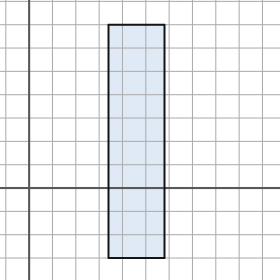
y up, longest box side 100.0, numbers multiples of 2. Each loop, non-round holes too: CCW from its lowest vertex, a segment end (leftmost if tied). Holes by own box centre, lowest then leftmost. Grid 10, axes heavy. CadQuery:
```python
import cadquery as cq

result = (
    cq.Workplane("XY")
    .moveTo(34.0, -30.0)
    .lineTo(58.0, -30.0)
    .lineTo(58.0, 70.0)
    .lineTo(34.0, 70.0)
    .close()
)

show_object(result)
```